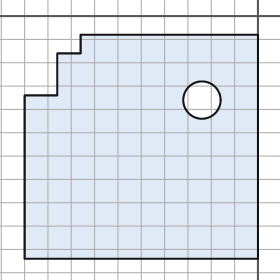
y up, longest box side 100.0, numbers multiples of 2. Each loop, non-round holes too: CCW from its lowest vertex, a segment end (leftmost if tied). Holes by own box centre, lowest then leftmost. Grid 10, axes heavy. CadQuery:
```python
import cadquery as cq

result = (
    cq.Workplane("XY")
    .moveTo(-100.0, -104.0)
    .lineTo(0.0, -104.0)
    .lineTo(0.0, -8.0)
    .lineTo(-76.0, -8.0)
    .lineTo(-76.0, -16.0)
    .lineTo(-86.0, -16.0)
    .lineTo(-86.0, -34.0)
    .lineTo(-100.0, -34.0)
    .close()
    .moveTo(-24.0, -36.0)
    .circle(8.0)
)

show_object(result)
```